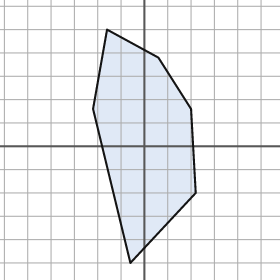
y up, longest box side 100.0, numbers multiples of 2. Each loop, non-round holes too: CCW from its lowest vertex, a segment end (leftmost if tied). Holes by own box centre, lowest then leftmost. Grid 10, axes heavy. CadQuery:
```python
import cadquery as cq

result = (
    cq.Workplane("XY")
    .moveTo(-6.0, -50.0)
    .lineTo(22.0, -20.0)
    .lineTo(20.0, 16.0)
    .lineTo(6.0, 38.0)
    .lineTo(-16.0, 50.0)
    .lineTo(-22.0, 16.0)
    .close()
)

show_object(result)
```